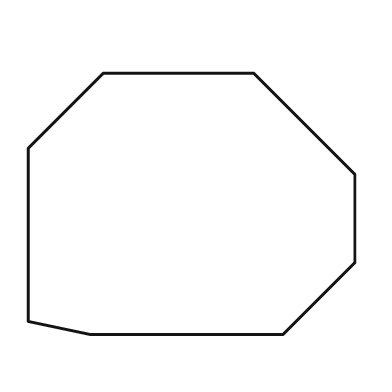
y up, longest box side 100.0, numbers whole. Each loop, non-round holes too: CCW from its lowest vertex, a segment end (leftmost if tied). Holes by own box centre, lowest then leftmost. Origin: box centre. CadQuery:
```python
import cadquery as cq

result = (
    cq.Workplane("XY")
    .moveTo(-31.0, -40.0)
    .lineTo(28.0, -40.0)
    .lineTo(50.0, -18.0)
    .lineTo(50.0, 9.0)
    .lineTo(19.0, 40.0)
    .lineTo(-27.0, 40.0)
    .lineTo(-50.0, 17.0)
    .lineTo(-50.0, -36.0)
    .close()
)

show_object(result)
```